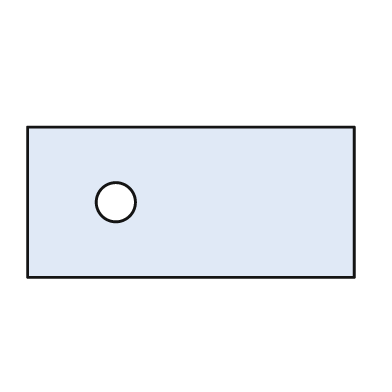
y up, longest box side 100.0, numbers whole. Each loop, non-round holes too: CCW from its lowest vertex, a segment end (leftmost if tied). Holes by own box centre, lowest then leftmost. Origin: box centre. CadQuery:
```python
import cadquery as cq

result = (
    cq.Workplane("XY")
    .moveTo(-50.0, -23.0)
    .lineTo(50.0, -23.0)
    .lineTo(50.0, 23.0)
    .lineTo(-50.0, 23.0)
    .close()
    .moveTo(-23.0, 0.0)
    .circle(6.0)
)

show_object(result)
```